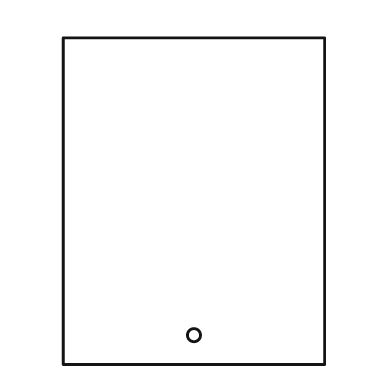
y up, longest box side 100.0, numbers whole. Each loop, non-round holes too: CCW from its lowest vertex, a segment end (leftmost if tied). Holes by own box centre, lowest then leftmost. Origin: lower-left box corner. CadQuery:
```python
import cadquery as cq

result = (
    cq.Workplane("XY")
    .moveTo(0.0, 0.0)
    .lineTo(80.0, 0.0)
    .lineTo(80.0, 100.0)
    .lineTo(0.0, 100.0)
    .close()
    .moveTo(40.0, 9.0)
    .circle(2.0)
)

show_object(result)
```